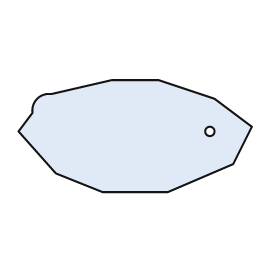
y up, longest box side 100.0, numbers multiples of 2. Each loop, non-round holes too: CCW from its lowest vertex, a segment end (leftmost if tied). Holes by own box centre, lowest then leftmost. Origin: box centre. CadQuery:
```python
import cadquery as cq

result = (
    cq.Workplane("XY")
    .moveTo(-14.0, -24.0)
    .lineTo(14.0, -24.0)
    .lineTo(42.0, -12.0)
    .lineTo(50.0, 4.0)
    .lineTo(34.0, 16.0)
    .lineTo(10.0, 24.0)
    .lineTo(-10.0, 24.0)
    .lineTo(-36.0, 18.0)
    .threePointArc((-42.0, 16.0), (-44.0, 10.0))
    .lineTo(-50.0, 2.0)
    .lineTo(-34.0, -16.0)
    .close()
    .moveTo(32.0, 2.0)
    .circle(2.0)
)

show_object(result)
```